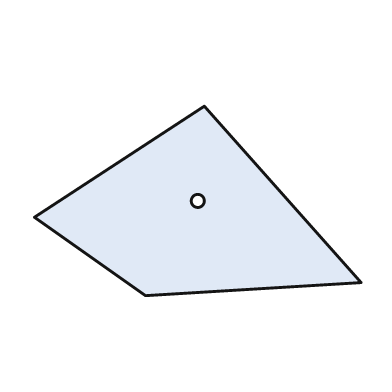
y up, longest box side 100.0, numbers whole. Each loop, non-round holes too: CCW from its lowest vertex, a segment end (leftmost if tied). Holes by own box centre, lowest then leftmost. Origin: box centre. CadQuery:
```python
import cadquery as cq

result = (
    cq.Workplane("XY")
    .moveTo(-16.0, -29.0)
    .lineTo(50.0, -25.0)
    .lineTo(2.0, 29.0)
    .lineTo(-50.0, -5.0)
    .close()
    .moveTo(0.0, 0.0)
    .circle(2.0)
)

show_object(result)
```